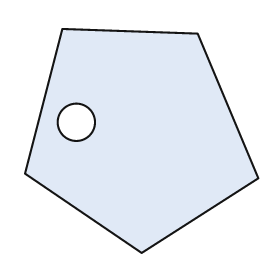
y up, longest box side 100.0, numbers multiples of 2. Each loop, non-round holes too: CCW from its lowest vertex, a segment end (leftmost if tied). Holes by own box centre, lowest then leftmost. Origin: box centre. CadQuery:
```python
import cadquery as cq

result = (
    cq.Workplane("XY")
    .moveTo(0.0, -48.0)
    .lineTo(50.0, -16.0)
    .lineTo(24.0, 46.0)
    .lineTo(-34.0, 48.0)
    .lineTo(-50.0, -14.0)
    .close()
    .moveTo(-28.0, 8.0)
    .circle(8.0)
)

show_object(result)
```